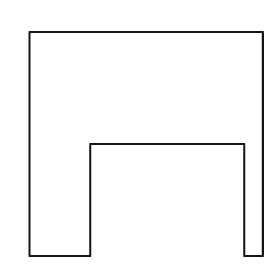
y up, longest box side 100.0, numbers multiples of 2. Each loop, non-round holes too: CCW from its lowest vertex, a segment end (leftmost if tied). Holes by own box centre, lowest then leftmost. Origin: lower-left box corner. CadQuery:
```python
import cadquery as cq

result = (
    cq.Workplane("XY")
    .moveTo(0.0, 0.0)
    .lineTo(26.0, 0.0)
    .lineTo(26.0, 48.0)
    .lineTo(92.0, 48.0)
    .lineTo(92.0, 0.0)
    .lineTo(100.0, 0.0)
    .lineTo(100.0, 96.0)
    .lineTo(0.0, 96.0)
    .close()
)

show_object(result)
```